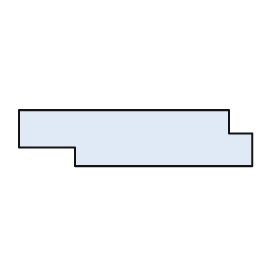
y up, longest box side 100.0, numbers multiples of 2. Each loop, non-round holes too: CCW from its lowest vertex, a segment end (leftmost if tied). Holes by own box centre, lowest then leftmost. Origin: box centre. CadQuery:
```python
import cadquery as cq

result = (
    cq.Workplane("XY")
    .moveTo(-26.0, -12.0)
    .lineTo(50.0, -12.0)
    .lineTo(50.0, 2.0)
    .lineTo(40.0, 2.0)
    .lineTo(40.0, 12.0)
    .lineTo(-50.0, 12.0)
    .lineTo(-50.0, -4.0)
    .lineTo(-26.0, -4.0)
    .close()
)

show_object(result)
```